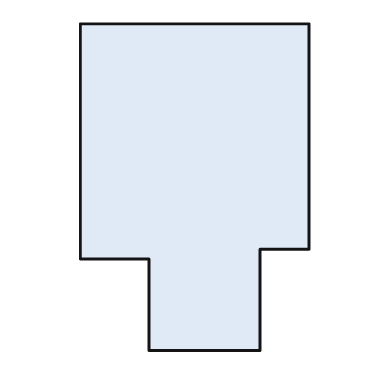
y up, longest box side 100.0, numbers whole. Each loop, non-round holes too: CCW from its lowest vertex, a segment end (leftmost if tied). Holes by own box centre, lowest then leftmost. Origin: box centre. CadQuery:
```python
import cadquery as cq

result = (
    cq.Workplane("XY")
    .moveTo(-14.0, -50.0)
    .lineTo(20.0, -50.0)
    .lineTo(20.0, -19.0)
    .lineTo(35.0, -19.0)
    .lineTo(35.0, 50.0)
    .lineTo(-35.0, 50.0)
    .lineTo(-35.0, -22.0)
    .lineTo(-14.0, -22.0)
    .close()
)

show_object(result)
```